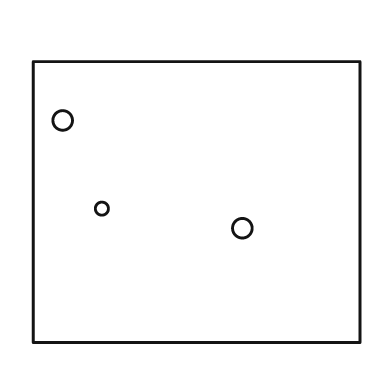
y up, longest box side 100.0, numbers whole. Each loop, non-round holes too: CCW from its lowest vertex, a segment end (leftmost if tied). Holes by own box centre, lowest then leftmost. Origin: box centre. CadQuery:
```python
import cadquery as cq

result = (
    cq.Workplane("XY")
    .moveTo(-50.0, -43.0)
    .lineTo(50.0, -43.0)
    .lineTo(50.0, 43.0)
    .lineTo(-50.0, 43.0)
    .close()
    .moveTo(14.0, -8.0)
    .circle(3.0)
    .moveTo(-29.0, -2.0)
    .circle(2.0)
    .moveTo(-41.0, 25.0)
    .circle(3.0)
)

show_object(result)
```